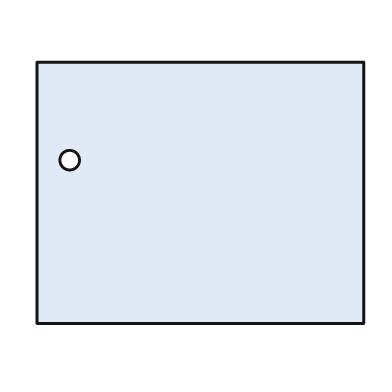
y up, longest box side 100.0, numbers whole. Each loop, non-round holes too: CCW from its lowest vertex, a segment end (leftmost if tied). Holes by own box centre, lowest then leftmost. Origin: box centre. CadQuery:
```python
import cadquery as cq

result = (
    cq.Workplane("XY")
    .moveTo(-50.0, -40.0)
    .lineTo(50.0, -40.0)
    .lineTo(50.0, 40.0)
    .lineTo(-50.0, 40.0)
    .close()
    .moveTo(-40.0, 10.0)
    .circle(3.0)
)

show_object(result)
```